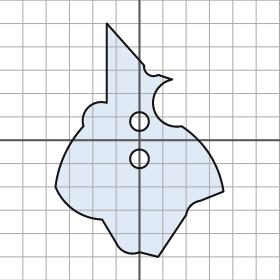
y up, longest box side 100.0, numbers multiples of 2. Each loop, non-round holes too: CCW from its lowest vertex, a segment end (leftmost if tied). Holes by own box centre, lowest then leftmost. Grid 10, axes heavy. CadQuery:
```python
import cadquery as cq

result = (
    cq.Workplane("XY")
    .moveTo(8.0, -50.0)
    .lineTo(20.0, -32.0)
    .threePointArc((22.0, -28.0), (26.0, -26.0))
    .lineTo(36.0, -22.0)
    .threePointArc((30.0, -6.0), (18.0, 6.0))
    .threePointArc((6.0, 14.0), (14.0, 26.0))
    .lineTo(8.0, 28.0)
    .threePointArc((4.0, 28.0), (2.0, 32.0))
    .lineTo(-14.0, 50.0)
    .lineTo(-14.0, 16.0)
    .threePointArc((-22.0, 14.0), (-24.0, 6.0))
    .threePointArc((-32.0, -6.0), (-36.0, -20.0))
    .threePointArc((-28.0, -30.0), (-16.0, -34.0))
    .lineTo(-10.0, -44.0)
    .threePointArc((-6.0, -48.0), (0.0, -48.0))
    .close()
    .moveTo(0.0, -8.0)
    .circle(4.0)
    .moveTo(0.0, 8.0)
    .circle(4.0)
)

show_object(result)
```